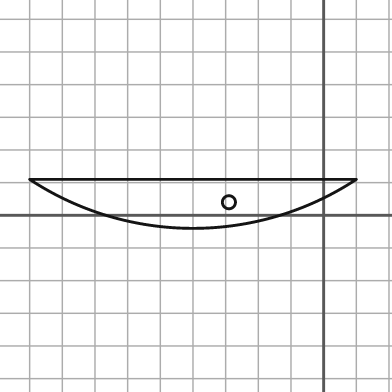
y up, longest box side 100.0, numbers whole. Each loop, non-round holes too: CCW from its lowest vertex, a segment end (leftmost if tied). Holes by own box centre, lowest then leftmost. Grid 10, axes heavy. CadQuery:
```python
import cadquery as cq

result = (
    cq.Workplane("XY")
    .moveTo(-90.0, 11.0)
    .threePointArc((-40.0, -4.0), (10.0, 11.0))
    .close()
    .moveTo(-29.0, 4.0)
    .circle(2.0)
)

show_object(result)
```